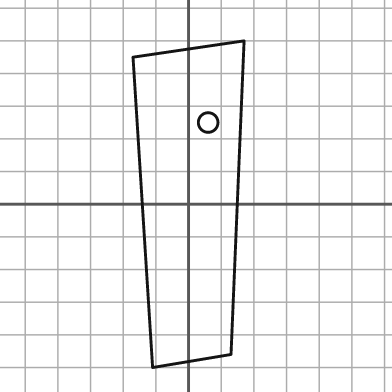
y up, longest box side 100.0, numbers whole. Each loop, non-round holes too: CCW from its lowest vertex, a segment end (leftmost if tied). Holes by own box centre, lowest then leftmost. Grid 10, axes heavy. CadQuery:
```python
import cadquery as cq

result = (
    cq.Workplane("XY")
    .moveTo(-11.0, -50.0)
    .lineTo(13.0, -46.0)
    .lineTo(17.0, 50.0)
    .lineTo(-17.0, 45.0)
    .close()
    .moveTo(6.0, 25.0)
    .circle(3.0)
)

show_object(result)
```